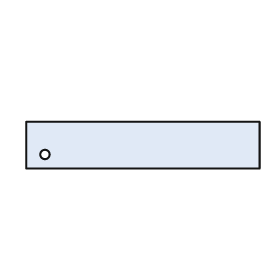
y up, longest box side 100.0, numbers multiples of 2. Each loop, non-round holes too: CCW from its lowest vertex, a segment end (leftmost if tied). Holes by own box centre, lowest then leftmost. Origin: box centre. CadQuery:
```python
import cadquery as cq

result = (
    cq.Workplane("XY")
    .moveTo(-50.0, -10.0)
    .lineTo(50.0, -10.0)
    .lineTo(50.0, 10.0)
    .lineTo(-50.0, 10.0)
    .close()
    .moveTo(-42.0, -4.0)
    .circle(2.0)
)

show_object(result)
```